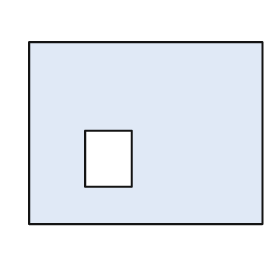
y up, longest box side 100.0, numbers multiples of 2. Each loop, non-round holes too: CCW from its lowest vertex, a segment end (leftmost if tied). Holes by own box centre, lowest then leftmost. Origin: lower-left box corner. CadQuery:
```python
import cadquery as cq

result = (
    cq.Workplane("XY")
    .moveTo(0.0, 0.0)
    .lineTo(100.0, 0.0)
    .lineTo(100.0, 78.0)
    .lineTo(0.0, 78.0)
    .close()
    .moveTo(24.0, 16.0)
    .lineTo(44.0, 16.0)
    .lineTo(44.0, 40.0)
    .lineTo(24.0, 40.0)
    .close()
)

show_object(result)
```